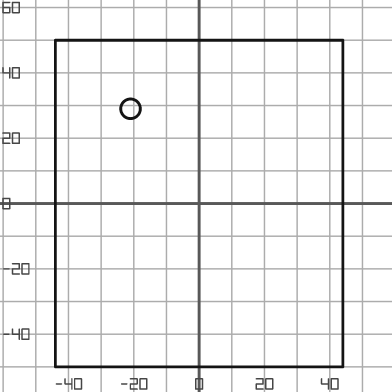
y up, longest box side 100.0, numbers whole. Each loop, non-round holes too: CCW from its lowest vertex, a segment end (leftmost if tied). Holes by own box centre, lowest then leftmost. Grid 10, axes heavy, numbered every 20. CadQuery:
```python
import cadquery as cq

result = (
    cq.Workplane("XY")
    .moveTo(-44.0, -50.0)
    .lineTo(44.0, -50.0)
    .lineTo(44.0, 50.0)
    .lineTo(-44.0, 50.0)
    .close()
    .moveTo(-21.0, 29.0)
    .circle(3.0)
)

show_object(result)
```